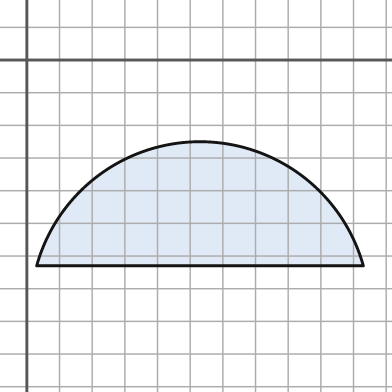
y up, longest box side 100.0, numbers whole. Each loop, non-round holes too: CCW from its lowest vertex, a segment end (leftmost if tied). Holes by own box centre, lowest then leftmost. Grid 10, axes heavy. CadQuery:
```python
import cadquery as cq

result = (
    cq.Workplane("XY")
    .moveTo(3.0, -63.0)
    .lineTo(103.0, -63.0)
    .threePointArc((53.0, -25.0), (3.0, -63.0))
    .close()
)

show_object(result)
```